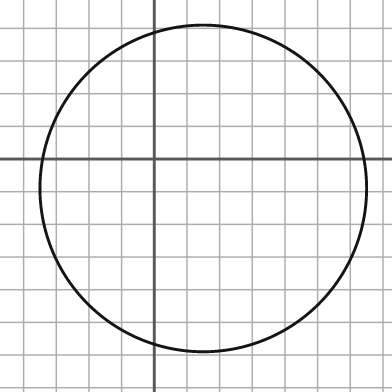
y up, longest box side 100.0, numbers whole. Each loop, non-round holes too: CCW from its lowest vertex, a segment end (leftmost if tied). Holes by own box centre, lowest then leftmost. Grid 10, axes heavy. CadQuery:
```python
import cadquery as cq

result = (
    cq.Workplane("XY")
    .moveTo(15.0, -9.0)
    .circle(50.0)
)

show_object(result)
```